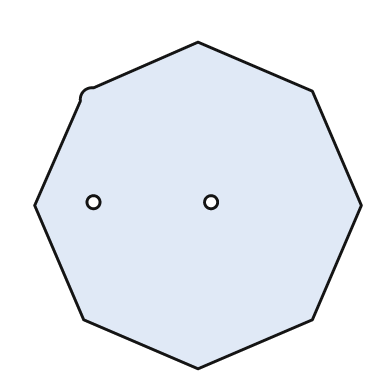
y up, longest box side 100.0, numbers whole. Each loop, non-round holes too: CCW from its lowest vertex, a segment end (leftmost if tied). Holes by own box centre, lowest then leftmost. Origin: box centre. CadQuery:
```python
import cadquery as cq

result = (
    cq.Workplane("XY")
    .moveTo(0.0, -50.0)
    .lineTo(35.0, -35.0)
    .lineTo(50.0, 0.0)
    .lineTo(35.0, 35.0)
    .lineTo(0.0, 50.0)
    .lineTo(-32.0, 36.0)
    .threePointArc((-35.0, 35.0), (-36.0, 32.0))
    .lineTo(-50.0, 0.0)
    .lineTo(-35.0, -35.0)
    .close()
    .moveTo(-32.0, 1.0)
    .circle(2.0)
    .moveTo(4.0, 1.0)
    .circle(2.0)
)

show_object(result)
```